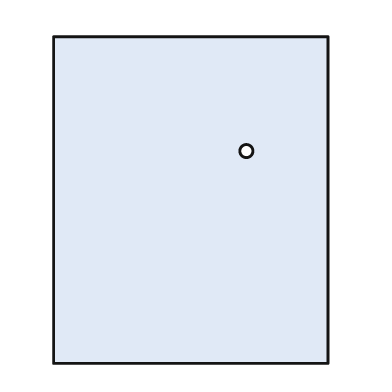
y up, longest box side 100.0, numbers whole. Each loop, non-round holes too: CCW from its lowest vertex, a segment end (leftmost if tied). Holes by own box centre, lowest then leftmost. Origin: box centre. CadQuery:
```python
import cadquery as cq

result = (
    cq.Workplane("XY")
    .moveTo(-42.0, -50.0)
    .lineTo(42.0, -50.0)
    .lineTo(42.0, 50.0)
    .lineTo(-42.0, 50.0)
    .close()
    .moveTo(17.0, 15.0)
    .circle(2.0)
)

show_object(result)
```